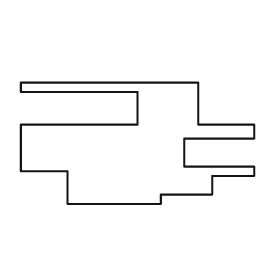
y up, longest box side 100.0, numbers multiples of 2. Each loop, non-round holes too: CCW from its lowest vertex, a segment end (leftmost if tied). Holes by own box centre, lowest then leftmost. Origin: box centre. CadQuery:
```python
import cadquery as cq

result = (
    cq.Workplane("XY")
    .moveTo(-30.0, -26.0)
    .lineTo(10.0, -26.0)
    .lineTo(10.0, -22.0)
    .lineTo(32.0, -22.0)
    .lineTo(32.0, -14.0)
    .lineTo(50.0, -14.0)
    .lineTo(50.0, -10.0)
    .lineTo(20.0, -10.0)
    .lineTo(20.0, 2.0)
    .lineTo(50.0, 2.0)
    .lineTo(50.0, 8.0)
    .lineTo(26.0, 8.0)
    .lineTo(26.0, 26.0)
    .lineTo(-50.0, 26.0)
    .lineTo(-50.0, 22.0)
    .lineTo(0.0, 22.0)
    .lineTo(0.0, 8.0)
    .lineTo(-50.0, 8.0)
    .lineTo(-50.0, -12.0)
    .lineTo(-30.0, -12.0)
    .close()
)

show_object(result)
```